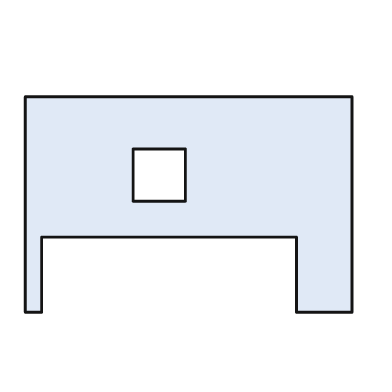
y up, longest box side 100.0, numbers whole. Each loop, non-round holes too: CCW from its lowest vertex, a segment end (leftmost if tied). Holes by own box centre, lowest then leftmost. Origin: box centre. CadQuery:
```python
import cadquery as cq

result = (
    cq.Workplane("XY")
    .moveTo(-50.0, -33.0)
    .lineTo(-45.0, -33.0)
    .lineTo(-45.0, -10.0)
    .lineTo(33.0, -10.0)
    .lineTo(33.0, -33.0)
    .lineTo(50.0, -33.0)
    .lineTo(50.0, 33.0)
    .lineTo(-50.0, 33.0)
    .close()
    .moveTo(-17.0, 1.0)
    .lineTo(-1.0, 1.0)
    .lineTo(-1.0, 17.0)
    .lineTo(-17.0, 17.0)
    .close()
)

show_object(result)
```